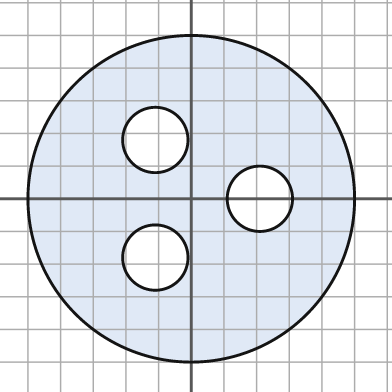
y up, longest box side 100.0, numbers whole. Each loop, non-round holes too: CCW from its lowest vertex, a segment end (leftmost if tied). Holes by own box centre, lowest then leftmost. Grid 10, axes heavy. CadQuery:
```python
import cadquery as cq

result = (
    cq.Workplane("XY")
    .moveTo(0.0, 0.0)
    .circle(50.0)
    .moveTo(-11.0, -18.0)
    .circle(10.0)
    .moveTo(21.0, 0.0)
    .circle(10.0)
    .moveTo(-11.0, 18.0)
    .circle(10.0)
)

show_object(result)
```